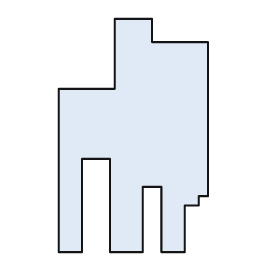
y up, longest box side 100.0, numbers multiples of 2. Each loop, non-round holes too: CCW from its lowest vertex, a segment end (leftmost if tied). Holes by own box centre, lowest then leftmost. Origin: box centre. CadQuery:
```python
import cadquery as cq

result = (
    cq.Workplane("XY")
    .moveTo(-32.0, -50.0)
    .lineTo(-22.0, -50.0)
    .lineTo(-22.0, -10.0)
    .lineTo(-10.0, -10.0)
    .lineTo(-10.0, -50.0)
    .lineTo(4.0, -50.0)
    .lineTo(4.0, -22.0)
    .lineTo(12.0, -22.0)
    .lineTo(12.0, -50.0)
    .lineTo(22.0, -50.0)
    .lineTo(22.0, -30.0)
    .lineTo(28.0, -30.0)
    .lineTo(28.0, -26.0)
    .lineTo(32.0, -26.0)
    .lineTo(32.0, 40.0)
    .lineTo(8.0, 40.0)
    .lineTo(8.0, 50.0)
    .lineTo(-8.0, 50.0)
    .lineTo(-8.0, 20.0)
    .lineTo(-32.0, 20.0)
    .close()
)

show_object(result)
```